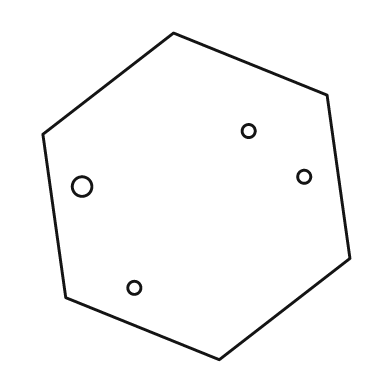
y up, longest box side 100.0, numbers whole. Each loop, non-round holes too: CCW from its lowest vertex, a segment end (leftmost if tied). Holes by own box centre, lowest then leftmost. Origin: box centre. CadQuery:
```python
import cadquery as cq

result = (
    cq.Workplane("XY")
    .moveTo(7.0, -50.0)
    .lineTo(47.0, -19.0)
    .lineTo(40.0, 31.0)
    .lineTo(-7.0, 50.0)
    .lineTo(-47.0, 19.0)
    .lineTo(-40.0, -31.0)
    .close()
    .moveTo(-19.0, -28.0)
    .circle(2.0)
    .moveTo(-35.0, 3.0)
    .circle(3.0)
    .moveTo(33.0, 6.0)
    .circle(2.0)
    .moveTo(16.0, 20.0)
    .circle(2.0)
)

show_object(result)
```